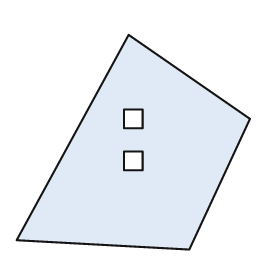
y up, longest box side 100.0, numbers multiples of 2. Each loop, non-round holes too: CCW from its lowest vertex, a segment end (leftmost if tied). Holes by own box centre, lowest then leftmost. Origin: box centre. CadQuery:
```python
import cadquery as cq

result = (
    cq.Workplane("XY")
    .moveTo(24.0, -46.0)
    .lineTo(50.0, 10.0)
    .lineTo(-2.0, 46.0)
    .lineTo(-50.0, -42.0)
    .close()
    .moveTo(-4.0, -12.0)
    .lineTo(4.0, -12.0)
    .lineTo(4.0, -4.0)
    .lineTo(-4.0, -4.0)
    .close()
    .moveTo(-4.0, 6.0)
    .lineTo(4.0, 6.0)
    .lineTo(4.0, 14.0)
    .lineTo(-4.0, 14.0)
    .close()
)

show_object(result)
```